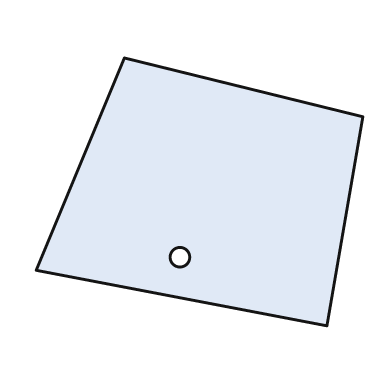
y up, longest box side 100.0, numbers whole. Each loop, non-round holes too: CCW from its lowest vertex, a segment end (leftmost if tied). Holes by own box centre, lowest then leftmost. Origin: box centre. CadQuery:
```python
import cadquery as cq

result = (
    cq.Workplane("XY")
    .moveTo(39.0, -41.0)
    .lineTo(50.0, 23.0)
    .lineTo(-23.0, 41.0)
    .lineTo(-50.0, -24.0)
    .close()
    .moveTo(-6.0, -20.0)
    .circle(3.0)
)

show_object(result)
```